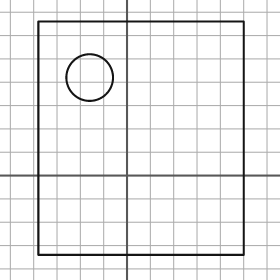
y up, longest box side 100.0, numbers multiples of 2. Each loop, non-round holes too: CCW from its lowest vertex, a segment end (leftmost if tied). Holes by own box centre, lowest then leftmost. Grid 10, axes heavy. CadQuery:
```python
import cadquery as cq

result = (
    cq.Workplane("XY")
    .moveTo(-38.0, -34.0)
    .lineTo(50.0, -34.0)
    .lineTo(50.0, 66.0)
    .lineTo(-38.0, 66.0)
    .close()
    .moveTo(-16.0, 42.0)
    .circle(10.0)
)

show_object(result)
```